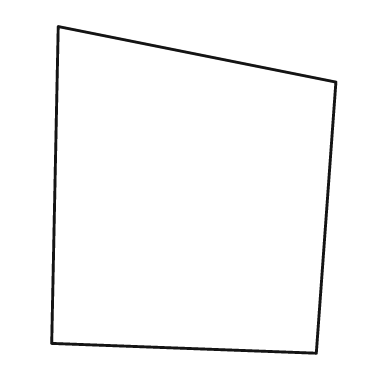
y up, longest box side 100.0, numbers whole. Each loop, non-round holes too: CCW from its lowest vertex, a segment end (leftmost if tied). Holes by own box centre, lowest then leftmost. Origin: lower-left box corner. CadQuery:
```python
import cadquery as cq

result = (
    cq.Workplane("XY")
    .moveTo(81.0, 0.0)
    .lineTo(87.0, 83.0)
    .lineTo(2.0, 100.0)
    .lineTo(0.0, 3.0)
    .close()
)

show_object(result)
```